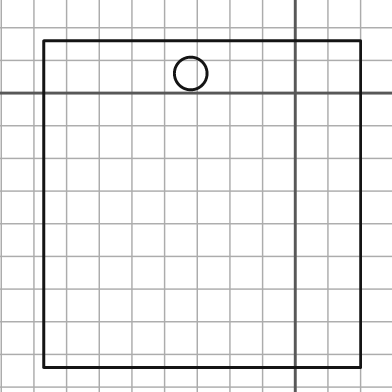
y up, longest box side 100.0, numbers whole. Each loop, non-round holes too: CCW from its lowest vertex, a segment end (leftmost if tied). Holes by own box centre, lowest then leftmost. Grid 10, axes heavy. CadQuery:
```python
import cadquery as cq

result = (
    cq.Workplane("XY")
    .moveTo(-77.0, -84.0)
    .lineTo(20.0, -84.0)
    .lineTo(20.0, 16.0)
    .lineTo(-77.0, 16.0)
    .close()
    .moveTo(-32.0, 6.0)
    .circle(5.0)
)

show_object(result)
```